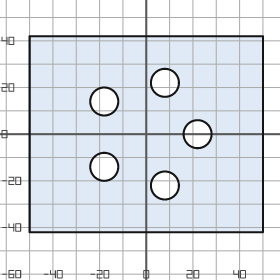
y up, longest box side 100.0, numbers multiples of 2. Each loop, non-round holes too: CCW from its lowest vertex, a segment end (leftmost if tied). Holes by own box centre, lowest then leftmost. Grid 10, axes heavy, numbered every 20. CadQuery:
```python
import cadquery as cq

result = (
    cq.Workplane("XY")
    .moveTo(-50.0, -42.0)
    .lineTo(50.0, -42.0)
    .lineTo(50.0, 42.0)
    .lineTo(-50.0, 42.0)
    .close()
    .moveTo(8.0, -22.0)
    .circle(6.0)
    .moveTo(-18.0, -14.0)
    .circle(6.0)
    .moveTo(22.0, 0.0)
    .circle(6.0)
    .moveTo(-18.0, 14.0)
    .circle(6.0)
    .moveTo(8.0, 22.0)
    .circle(6.0)
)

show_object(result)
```